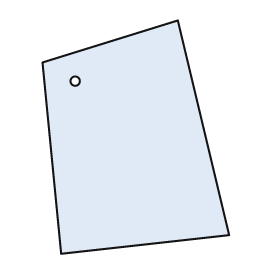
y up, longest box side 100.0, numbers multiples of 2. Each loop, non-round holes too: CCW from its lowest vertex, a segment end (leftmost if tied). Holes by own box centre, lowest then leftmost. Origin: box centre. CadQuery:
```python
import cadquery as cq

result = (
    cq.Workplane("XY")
    .moveTo(-32.0, -50.0)
    .lineTo(40.0, -42.0)
    .lineTo(18.0, 50.0)
    .lineTo(-40.0, 32.0)
    .close()
    .moveTo(-26.0, 24.0)
    .circle(2.0)
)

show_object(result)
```